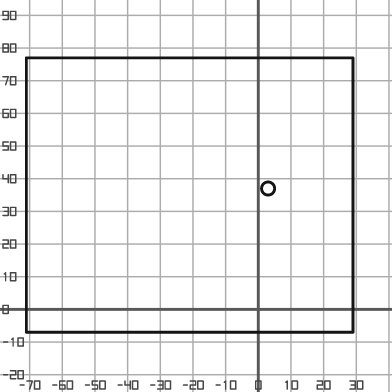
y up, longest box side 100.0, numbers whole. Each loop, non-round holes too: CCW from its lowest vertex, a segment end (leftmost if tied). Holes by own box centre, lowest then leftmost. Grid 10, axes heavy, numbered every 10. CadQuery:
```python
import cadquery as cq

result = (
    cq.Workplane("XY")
    .moveTo(-71.0, -7.0)
    .lineTo(29.0, -7.0)
    .lineTo(29.0, 77.0)
    .lineTo(-71.0, 77.0)
    .close()
    .moveTo(3.0, 37.0)
    .circle(2.0)
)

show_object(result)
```